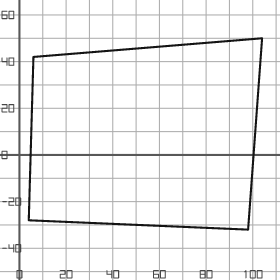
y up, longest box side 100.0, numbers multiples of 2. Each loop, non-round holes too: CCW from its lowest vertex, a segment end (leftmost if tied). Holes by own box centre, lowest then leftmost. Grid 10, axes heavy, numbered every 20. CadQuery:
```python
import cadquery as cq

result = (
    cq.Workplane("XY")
    .moveTo(98.0, -32.0)
    .lineTo(104.0, 50.0)
    .lineTo(6.0, 42.0)
    .lineTo(4.0, -28.0)
    .close()
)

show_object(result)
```